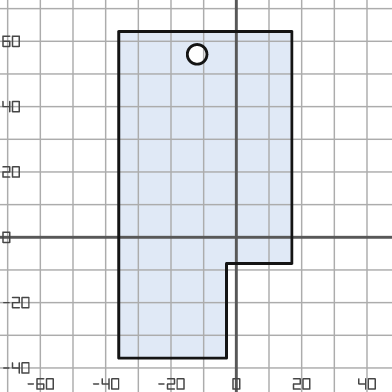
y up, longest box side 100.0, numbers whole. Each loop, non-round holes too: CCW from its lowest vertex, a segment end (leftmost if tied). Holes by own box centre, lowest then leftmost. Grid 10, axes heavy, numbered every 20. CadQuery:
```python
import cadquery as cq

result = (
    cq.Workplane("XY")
    .moveTo(-36.0, -37.0)
    .lineTo(-3.0, -37.0)
    .lineTo(-3.0, -8.0)
    .lineTo(17.0, -8.0)
    .lineTo(17.0, 63.0)
    .lineTo(-36.0, 63.0)
    .close()
    .moveTo(-12.0, 56.0)
    .circle(3.0)
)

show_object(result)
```